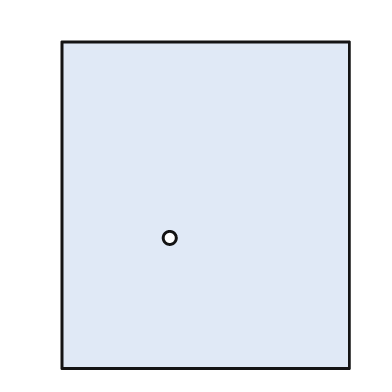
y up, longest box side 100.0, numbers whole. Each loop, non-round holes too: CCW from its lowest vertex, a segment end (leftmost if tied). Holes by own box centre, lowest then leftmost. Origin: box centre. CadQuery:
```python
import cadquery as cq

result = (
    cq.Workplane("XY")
    .moveTo(-44.0, -50.0)
    .lineTo(44.0, -50.0)
    .lineTo(44.0, 50.0)
    .lineTo(-44.0, 50.0)
    .close()
    .moveTo(-11.0, -10.0)
    .circle(2.0)
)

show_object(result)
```